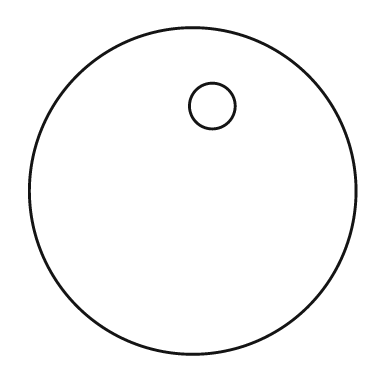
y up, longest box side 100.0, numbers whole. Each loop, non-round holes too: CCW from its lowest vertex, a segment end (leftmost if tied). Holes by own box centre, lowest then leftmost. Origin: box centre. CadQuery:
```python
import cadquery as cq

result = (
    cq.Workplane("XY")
    .moveTo(0.0, 0.0)
    .circle(50.0)
    .moveTo(6.0, 26.0)
    .circle(7.0)
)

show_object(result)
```